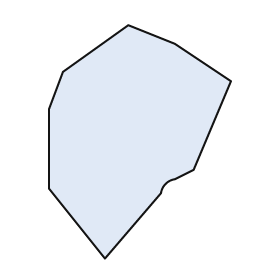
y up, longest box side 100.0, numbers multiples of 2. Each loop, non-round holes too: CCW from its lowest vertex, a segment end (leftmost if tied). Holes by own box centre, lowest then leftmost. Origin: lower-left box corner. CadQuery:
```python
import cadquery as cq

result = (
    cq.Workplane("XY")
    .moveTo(24.0, 0.0)
    .lineTo(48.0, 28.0)
    .threePointArc((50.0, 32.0), (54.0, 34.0))
    .lineTo(62.0, 38.0)
    .lineTo(78.0, 76.0)
    .lineTo(54.0, 92.0)
    .lineTo(34.0, 100.0)
    .lineTo(6.0, 80.0)
    .lineTo(0.0, 64.0)
    .lineTo(0.0, 30.0)
    .close()
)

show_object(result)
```